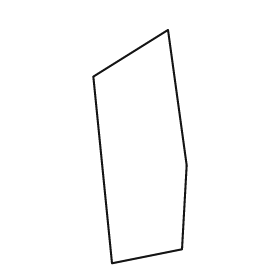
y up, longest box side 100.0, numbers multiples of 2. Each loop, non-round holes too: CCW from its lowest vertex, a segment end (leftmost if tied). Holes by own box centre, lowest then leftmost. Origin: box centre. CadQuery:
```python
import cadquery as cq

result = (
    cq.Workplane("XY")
    .moveTo(-12.0, -50.0)
    .lineTo(18.0, -44.0)
    .lineTo(20.0, -8.0)
    .lineTo(12.0, 50.0)
    .lineTo(-20.0, 30.0)
    .close()
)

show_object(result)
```